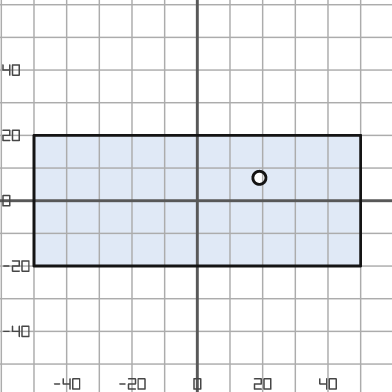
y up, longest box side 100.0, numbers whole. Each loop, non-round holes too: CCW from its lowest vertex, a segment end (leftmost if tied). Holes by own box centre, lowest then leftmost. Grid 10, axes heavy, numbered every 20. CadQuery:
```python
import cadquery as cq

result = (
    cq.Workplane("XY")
    .moveTo(-50.0, -20.0)
    .lineTo(50.0, -20.0)
    .lineTo(50.0, 20.0)
    .lineTo(-50.0, 20.0)
    .close()
    .moveTo(19.0, 7.0)
    .circle(2.0)
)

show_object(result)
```